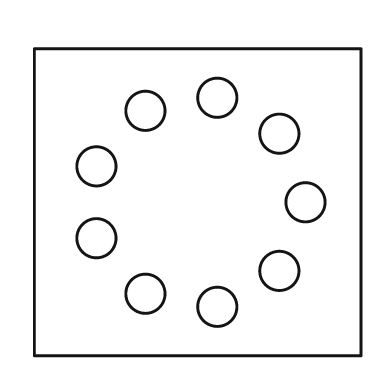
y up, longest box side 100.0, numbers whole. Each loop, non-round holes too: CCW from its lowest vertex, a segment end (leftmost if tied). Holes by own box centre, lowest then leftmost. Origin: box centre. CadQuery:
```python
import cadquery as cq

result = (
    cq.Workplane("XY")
    .moveTo(-50.0, -47.0)
    .lineTo(50.0, -47.0)
    .lineTo(50.0, 47.0)
    .lineTo(-50.0, 47.0)
    .close()
    .moveTo(6.0, -32.0)
    .circle(6.0)
    .moveTo(-16.0, -28.0)
    .circle(6.0)
    .moveTo(25.0, -21.0)
    .circle(6.0)
    .moveTo(-31.0, -11.0)
    .circle(6.0)
    .moveTo(33.0, 0.0)
    .circle(6.0)
    .moveTo(-31.0, 11.0)
    .circle(6.0)
    .moveTo(25.0, 21.0)
    .circle(6.0)
    .moveTo(-16.0, 28.0)
    .circle(6.0)
    .moveTo(6.0, 32.0)
    .circle(6.0)
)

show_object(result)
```